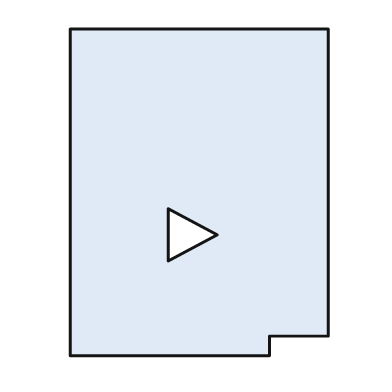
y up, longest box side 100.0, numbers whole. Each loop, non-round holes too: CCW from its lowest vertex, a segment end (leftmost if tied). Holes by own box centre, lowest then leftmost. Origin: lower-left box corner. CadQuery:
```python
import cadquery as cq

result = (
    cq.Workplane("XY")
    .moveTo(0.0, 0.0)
    .lineTo(61.0, 0.0)
    .lineTo(61.0, 6.0)
    .lineTo(79.0, 6.0)
    .lineTo(79.0, 100.0)
    .lineTo(0.0, 100.0)
    .close()
    .moveTo(30.0, 29.0)
    .lineTo(45.0, 37.0)
    .lineTo(30.0, 45.0)
    .close()
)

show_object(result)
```